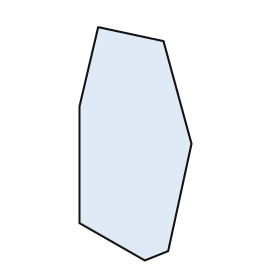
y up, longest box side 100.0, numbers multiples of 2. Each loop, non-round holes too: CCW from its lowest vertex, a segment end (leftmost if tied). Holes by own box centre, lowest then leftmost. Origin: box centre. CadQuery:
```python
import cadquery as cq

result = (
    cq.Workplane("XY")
    .moveTo(4.0, -50.0)
    .lineTo(14.0, -46.0)
    .lineTo(24.0, 0.0)
    .lineTo(12.0, 44.0)
    .lineTo(-16.0, 50.0)
    .lineTo(-24.0, 16.0)
    .lineTo(-24.0, -34.0)
    .close()
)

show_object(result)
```